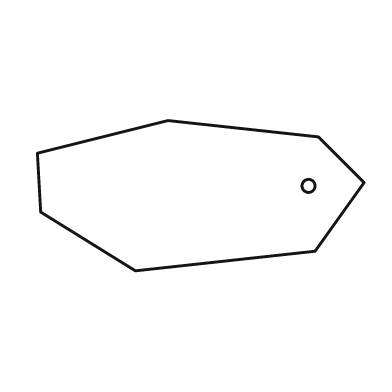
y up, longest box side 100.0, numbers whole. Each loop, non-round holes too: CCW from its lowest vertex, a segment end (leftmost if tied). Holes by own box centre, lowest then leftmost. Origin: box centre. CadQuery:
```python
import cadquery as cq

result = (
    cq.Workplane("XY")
    .moveTo(-20.0, -23.0)
    .lineTo(35.0, -17.0)
    .lineTo(50.0, 4.0)
    .lineTo(36.0, 18.0)
    .lineTo(-10.0, 23.0)
    .lineTo(-50.0, 13.0)
    .lineTo(-49.0, -5.0)
    .close()
    .moveTo(33.0, 3.0)
    .circle(2.0)
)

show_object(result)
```